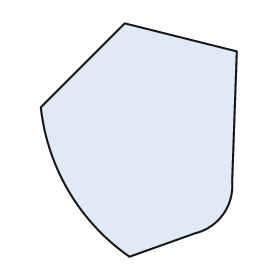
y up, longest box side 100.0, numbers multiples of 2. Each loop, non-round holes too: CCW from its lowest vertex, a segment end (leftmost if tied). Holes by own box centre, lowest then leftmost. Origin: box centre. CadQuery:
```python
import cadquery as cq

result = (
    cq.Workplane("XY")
    .moveTo(-4.0, -50.0)
    .lineTo(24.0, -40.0)
    .threePointArc((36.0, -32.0), (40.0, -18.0))
    .lineTo(42.0, 38.0)
    .lineTo(-6.0, 50.0)
    .lineTo(-42.0, 14.0)
    .threePointArc((-30.0, -22.0), (-4.0, -50.0))
    .close()
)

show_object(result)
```